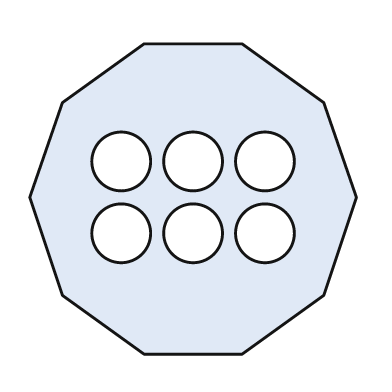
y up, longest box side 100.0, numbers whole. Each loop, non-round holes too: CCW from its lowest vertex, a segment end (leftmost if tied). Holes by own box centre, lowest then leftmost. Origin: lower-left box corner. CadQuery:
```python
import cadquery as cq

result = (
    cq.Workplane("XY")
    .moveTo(35.0, 0.0)
    .lineTo(65.0, 0.0)
    .lineTo(90.0, 18.0)
    .lineTo(100.0, 48.0)
    .lineTo(90.0, 77.0)
    .lineTo(65.0, 95.0)
    .lineTo(35.0, 95.0)
    .lineTo(10.0, 77.0)
    .lineTo(0.0, 48.0)
    .lineTo(10.0, 18.0)
    .close()
    .moveTo(28.0, 37.0)
    .circle(9.0)
    .moveTo(50.0, 37.0)
    .circle(9.0)
    .moveTo(72.0, 37.0)
    .circle(9.0)
    .moveTo(28.0, 59.0)
    .circle(9.0)
    .moveTo(50.0, 59.0)
    .circle(9.0)
    .moveTo(72.0, 59.0)
    .circle(9.0)
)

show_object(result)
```